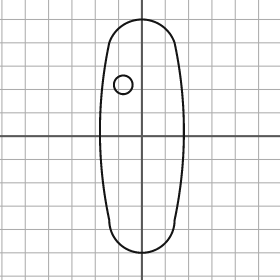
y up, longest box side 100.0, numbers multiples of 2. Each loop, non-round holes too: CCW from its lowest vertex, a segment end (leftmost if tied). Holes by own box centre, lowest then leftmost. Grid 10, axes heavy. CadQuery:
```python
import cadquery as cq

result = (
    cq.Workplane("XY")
    .moveTo(-14.0, -36.0)
    .threePointArc((0.0, -50.0), (14.0, -36.0))
    .threePointArc((18.0, 2.0), (14.0, 40.0))
    .threePointArc((0.0, 50.0), (-14.0, 40.0))
    .threePointArc((-18.0, 2.0), (-14.0, -36.0))
    .close()
    .moveTo(-8.0, 22.0)
    .circle(4.0)
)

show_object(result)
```